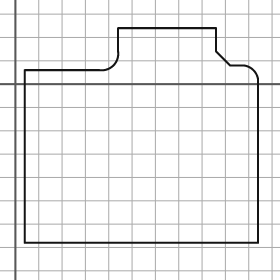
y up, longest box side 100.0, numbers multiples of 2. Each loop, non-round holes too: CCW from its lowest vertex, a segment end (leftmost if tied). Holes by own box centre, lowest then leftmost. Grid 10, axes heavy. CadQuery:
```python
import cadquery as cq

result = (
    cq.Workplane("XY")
    .moveTo(4.0, -68.0)
    .lineTo(104.0, -68.0)
    .lineTo(104.0, 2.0)
    .threePointArc((102.0, 6.0), (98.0, 8.0))
    .lineTo(92.0, 8.0)
    .lineTo(86.0, 14.0)
    .lineTo(86.0, 24.0)
    .lineTo(44.0, 24.0)
    .lineTo(44.0, 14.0)
    .threePointArc((42.0, 8.0), (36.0, 6.0))
    .lineTo(4.0, 6.0)
    .close()
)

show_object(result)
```